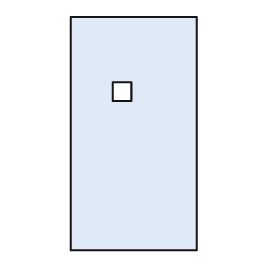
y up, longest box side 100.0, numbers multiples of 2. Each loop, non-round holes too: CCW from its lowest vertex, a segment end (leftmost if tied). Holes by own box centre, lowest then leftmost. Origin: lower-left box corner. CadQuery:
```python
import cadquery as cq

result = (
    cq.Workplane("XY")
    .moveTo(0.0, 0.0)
    .lineTo(54.0, 0.0)
    .lineTo(54.0, 100.0)
    .lineTo(0.0, 100.0)
    .close()
    .moveTo(18.0, 64.0)
    .lineTo(26.0, 64.0)
    .lineTo(26.0, 72.0)
    .lineTo(18.0, 72.0)
    .close()
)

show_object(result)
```